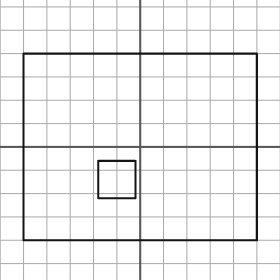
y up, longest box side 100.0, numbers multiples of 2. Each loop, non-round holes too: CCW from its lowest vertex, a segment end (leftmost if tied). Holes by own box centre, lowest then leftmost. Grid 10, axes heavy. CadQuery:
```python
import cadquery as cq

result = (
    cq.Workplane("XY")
    .moveTo(-50.0, -40.0)
    .lineTo(50.0, -40.0)
    .lineTo(50.0, 40.0)
    .lineTo(-50.0, 40.0)
    .close()
    .moveTo(-18.0, -22.0)
    .lineTo(-2.0, -22.0)
    .lineTo(-2.0, -6.0)
    .lineTo(-18.0, -6.0)
    .close()
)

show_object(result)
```